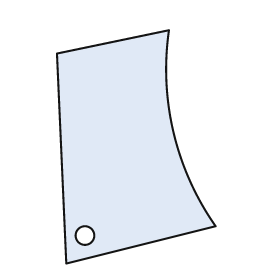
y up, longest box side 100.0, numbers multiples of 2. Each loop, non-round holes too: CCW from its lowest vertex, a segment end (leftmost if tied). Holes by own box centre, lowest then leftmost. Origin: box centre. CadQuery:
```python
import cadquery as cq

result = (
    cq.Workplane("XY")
    .moveTo(-30.0, -50.0)
    .lineTo(34.0, -34.0)
    .threePointArc((16.0, 6.0), (14.0, 50.0))
    .lineTo(-34.0, 40.0)
    .close()
    .moveTo(-22.0, -38.0)
    .circle(4.0)
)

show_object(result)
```